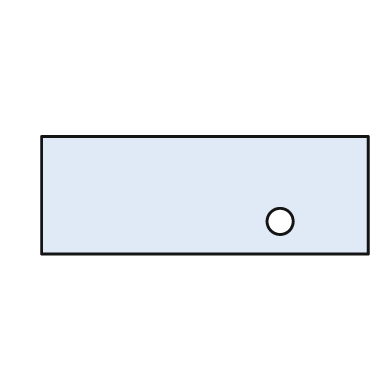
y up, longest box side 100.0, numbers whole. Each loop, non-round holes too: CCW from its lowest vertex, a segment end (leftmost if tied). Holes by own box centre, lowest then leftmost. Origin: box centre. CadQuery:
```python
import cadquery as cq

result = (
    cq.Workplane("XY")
    .moveTo(-50.0, -18.0)
    .lineTo(50.0, -18.0)
    .lineTo(50.0, 18.0)
    .lineTo(-50.0, 18.0)
    .close()
    .moveTo(23.0, -8.0)
    .circle(4.0)
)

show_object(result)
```